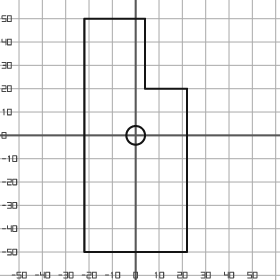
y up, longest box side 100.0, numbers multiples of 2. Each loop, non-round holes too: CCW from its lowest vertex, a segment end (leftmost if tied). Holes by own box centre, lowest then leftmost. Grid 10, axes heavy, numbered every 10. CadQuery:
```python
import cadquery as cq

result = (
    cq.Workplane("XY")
    .moveTo(-22.0, -50.0)
    .lineTo(22.0, -50.0)
    .lineTo(22.0, 20.0)
    .lineTo(4.0, 20.0)
    .lineTo(4.0, 50.0)
    .lineTo(-22.0, 50.0)
    .close()
    .moveTo(0.0, 0.0)
    .circle(4.0)
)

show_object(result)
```